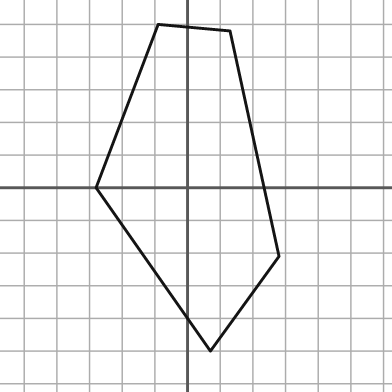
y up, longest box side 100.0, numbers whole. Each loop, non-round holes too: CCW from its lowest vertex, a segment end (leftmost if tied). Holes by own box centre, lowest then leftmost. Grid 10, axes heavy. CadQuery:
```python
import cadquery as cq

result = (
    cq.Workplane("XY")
    .moveTo(7.0, -50.0)
    .lineTo(28.0, -21.0)
    .lineTo(13.0, 48.0)
    .lineTo(-9.0, 50.0)
    .lineTo(-28.0, 0.0)
    .close()
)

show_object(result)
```